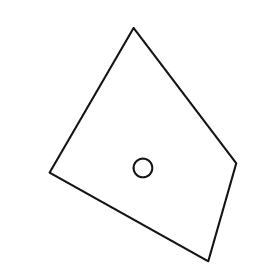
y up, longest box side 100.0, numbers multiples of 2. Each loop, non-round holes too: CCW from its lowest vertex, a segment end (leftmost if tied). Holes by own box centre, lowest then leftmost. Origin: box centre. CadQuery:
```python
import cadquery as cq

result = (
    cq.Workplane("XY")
    .moveTo(28.0, -50.0)
    .lineTo(40.0, -8.0)
    .lineTo(-4.0, 50.0)
    .lineTo(-40.0, -12.0)
    .close()
    .moveTo(0.0, -10.0)
    .circle(4.0)
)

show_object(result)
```